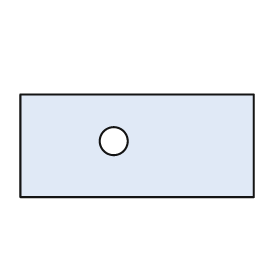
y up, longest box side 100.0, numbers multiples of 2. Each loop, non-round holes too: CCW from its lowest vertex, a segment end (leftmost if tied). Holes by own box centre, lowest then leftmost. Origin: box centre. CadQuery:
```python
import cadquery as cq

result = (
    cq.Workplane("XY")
    .moveTo(-50.0, -22.0)
    .lineTo(50.0, -22.0)
    .lineTo(50.0, 22.0)
    .lineTo(-50.0, 22.0)
    .close()
    .moveTo(-10.0, 2.0)
    .circle(6.0)
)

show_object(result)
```